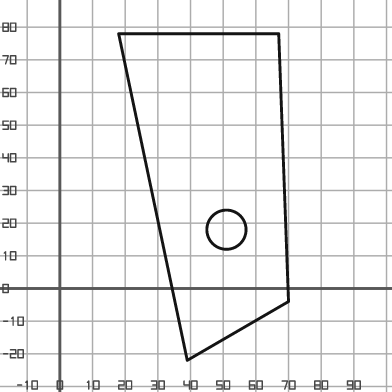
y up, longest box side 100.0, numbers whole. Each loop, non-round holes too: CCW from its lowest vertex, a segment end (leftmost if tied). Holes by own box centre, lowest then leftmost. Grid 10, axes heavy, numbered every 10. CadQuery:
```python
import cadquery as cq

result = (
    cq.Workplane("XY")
    .moveTo(39.0, -22.0)
    .lineTo(70.0, -4.0)
    .lineTo(67.0, 78.0)
    .lineTo(18.0, 78.0)
    .close()
    .moveTo(51.0, 18.0)
    .circle(6.0)
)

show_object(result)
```